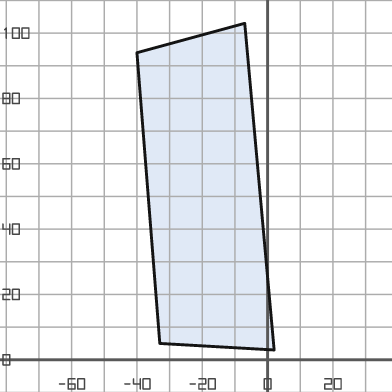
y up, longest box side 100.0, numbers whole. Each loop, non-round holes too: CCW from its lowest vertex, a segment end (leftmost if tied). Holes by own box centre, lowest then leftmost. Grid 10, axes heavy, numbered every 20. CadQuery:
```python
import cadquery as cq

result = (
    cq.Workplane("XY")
    .moveTo(2.0, 3.0)
    .lineTo(-7.0, 103.0)
    .lineTo(-40.0, 94.0)
    .lineTo(-33.0, 5.0)
    .close()
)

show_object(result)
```